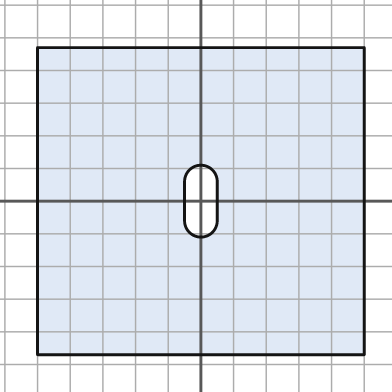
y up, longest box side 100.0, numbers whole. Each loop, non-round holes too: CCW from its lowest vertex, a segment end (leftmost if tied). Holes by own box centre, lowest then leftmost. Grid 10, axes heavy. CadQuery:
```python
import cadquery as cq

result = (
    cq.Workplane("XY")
    .moveTo(-50.0, -47.0)
    .lineTo(50.0, -47.0)
    .lineTo(50.0, 47.0)
    .lineTo(-50.0, 47.0)
    .close()
    .moveTo(-5.0, -6.0)
    .threePointArc((0.0, -11.0), (5.0, -6.0))
    .lineTo(5.0, 6.0)
    .threePointArc((0.0, 11.0), (-5.0, 6.0))
    .close()
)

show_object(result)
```